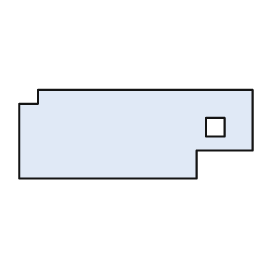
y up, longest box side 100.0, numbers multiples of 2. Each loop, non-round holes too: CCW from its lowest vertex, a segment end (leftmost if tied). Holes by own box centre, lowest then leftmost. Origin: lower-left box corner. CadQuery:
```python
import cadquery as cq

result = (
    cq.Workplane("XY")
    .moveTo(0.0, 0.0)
    .lineTo(76.0, 0.0)
    .lineTo(76.0, 12.0)
    .lineTo(100.0, 12.0)
    .lineTo(100.0, 38.0)
    .lineTo(8.0, 38.0)
    .lineTo(8.0, 32.0)
    .lineTo(0.0, 32.0)
    .close()
    .moveTo(80.0, 18.0)
    .lineTo(88.0, 18.0)
    .lineTo(88.0, 26.0)
    .lineTo(80.0, 26.0)
    .close()
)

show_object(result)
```